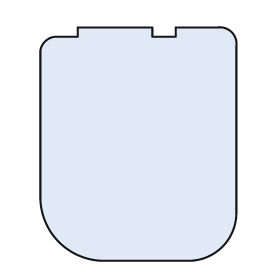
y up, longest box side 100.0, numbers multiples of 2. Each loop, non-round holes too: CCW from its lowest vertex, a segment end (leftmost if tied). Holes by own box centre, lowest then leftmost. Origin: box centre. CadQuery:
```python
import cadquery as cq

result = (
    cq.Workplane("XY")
    .moveTo(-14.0, -50.0)
    .lineTo(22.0, -50.0)
    .threePointArc((36.0, -44.0), (42.0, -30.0))
    .lineTo(42.0, 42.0)
    .threePointArc((40.0, 48.0), (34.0, 50.0))
    .lineTo(16.0, 50.0)
    .lineTo(16.0, 46.0)
    .lineTo(6.0, 46.0)
    .lineTo(6.0, 50.0)
    .lineTo(-26.0, 50.0)
    .lineTo(-26.0, 46.0)
    .lineTo(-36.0, 46.0)
    .threePointArc((-40.0, 44.0), (-42.0, 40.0))
    .lineTo(-42.0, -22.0)
    .threePointArc((-34.0, -42.0), (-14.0, -50.0))
    .close()
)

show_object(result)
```